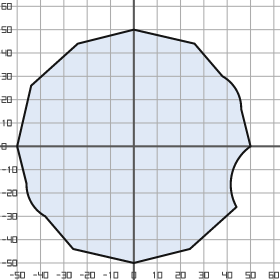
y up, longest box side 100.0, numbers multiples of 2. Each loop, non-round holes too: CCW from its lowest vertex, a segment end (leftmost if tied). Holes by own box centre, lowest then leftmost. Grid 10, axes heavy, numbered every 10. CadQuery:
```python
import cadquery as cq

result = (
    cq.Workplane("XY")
    .moveTo(0.0, -50.0)
    .lineTo(24.0, -44.0)
    .lineTo(44.0, -26.0)
    .threePointArc((42.0, -12.0), (50.0, 0.0))
    .lineTo(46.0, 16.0)
    .threePointArc((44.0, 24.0), (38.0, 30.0))
    .lineTo(26.0, 44.0)
    .lineTo(0.0, 50.0)
    .lineTo(-24.0, 44.0)
    .lineTo(-44.0, 26.0)
    .lineTo(-50.0, 0.0)
    .lineTo(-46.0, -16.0)
    .threePointArc((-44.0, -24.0), (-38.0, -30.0))
    .lineTo(-26.0, -44.0)
    .close()
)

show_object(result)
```